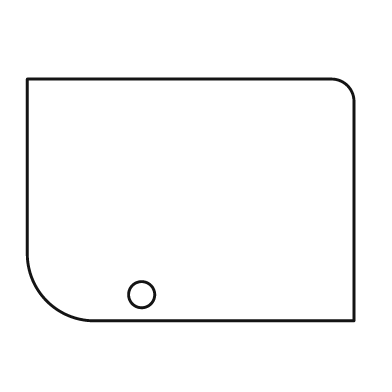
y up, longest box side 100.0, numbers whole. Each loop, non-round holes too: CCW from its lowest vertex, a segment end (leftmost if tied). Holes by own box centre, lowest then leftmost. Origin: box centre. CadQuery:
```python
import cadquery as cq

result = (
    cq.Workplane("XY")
    .moveTo(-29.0, -37.0)
    .lineTo(50.0, -37.0)
    .lineTo(50.0, 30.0)
    .threePointArc((48.0, 35.0), (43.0, 37.0))
    .lineTo(-50.0, 37.0)
    .lineTo(-50.0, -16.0)
    .threePointArc((-44.0, -31.0), (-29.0, -37.0))
    .close()
    .moveTo(-15.0, -29.0)
    .circle(4.0)
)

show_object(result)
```